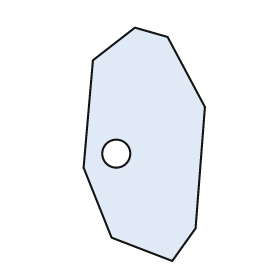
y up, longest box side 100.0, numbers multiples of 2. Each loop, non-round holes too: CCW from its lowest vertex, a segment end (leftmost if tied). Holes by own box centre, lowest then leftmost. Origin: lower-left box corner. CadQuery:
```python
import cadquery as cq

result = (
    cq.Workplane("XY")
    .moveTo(38.0, 0.0)
    .lineTo(48.0, 14.0)
    .lineTo(52.0, 66.0)
    .lineTo(36.0, 96.0)
    .lineTo(22.0, 100.0)
    .lineTo(4.0, 86.0)
    .lineTo(0.0, 40.0)
    .lineTo(12.0, 10.0)
    .close()
    .moveTo(14.0, 46.0)
    .circle(6.0)
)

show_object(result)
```